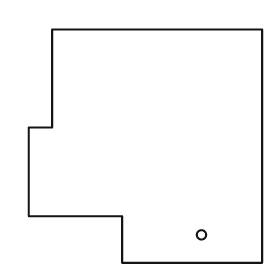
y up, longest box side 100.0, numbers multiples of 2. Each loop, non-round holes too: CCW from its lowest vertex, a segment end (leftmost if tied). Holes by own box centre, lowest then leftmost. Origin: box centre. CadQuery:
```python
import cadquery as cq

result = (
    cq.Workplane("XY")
    .moveTo(-10.0, -50.0)
    .lineTo(50.0, -50.0)
    .lineTo(50.0, 50.0)
    .lineTo(-40.0, 50.0)
    .lineTo(-40.0, 8.0)
    .lineTo(-50.0, 8.0)
    .lineTo(-50.0, -30.0)
    .lineTo(-10.0, -30.0)
    .close()
    .moveTo(24.0, -38.0)
    .circle(2.0)
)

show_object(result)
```